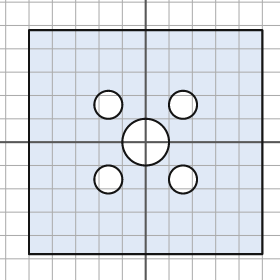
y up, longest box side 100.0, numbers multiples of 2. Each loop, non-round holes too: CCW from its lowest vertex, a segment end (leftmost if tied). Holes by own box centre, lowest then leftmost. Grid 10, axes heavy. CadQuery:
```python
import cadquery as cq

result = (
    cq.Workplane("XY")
    .moveTo(-50.0, -48.0)
    .lineTo(50.0, -48.0)
    .lineTo(50.0, 48.0)
    .lineTo(-50.0, 48.0)
    .close()
    .moveTo(-16.0, -16.0)
    .circle(6.0)
    .moveTo(16.0, -16.0)
    .circle(6.0)
    .moveTo(0.0, 0.0)
    .circle(10.0)
    .moveTo(-16.0, 16.0)
    .circle(6.0)
    .moveTo(16.0, 16.0)
    .circle(6.0)
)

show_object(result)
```